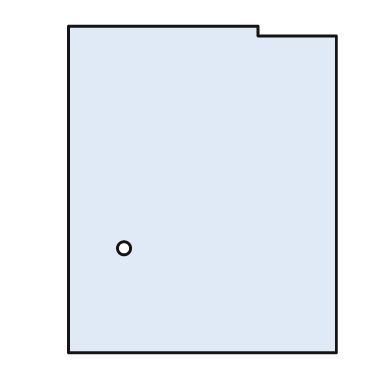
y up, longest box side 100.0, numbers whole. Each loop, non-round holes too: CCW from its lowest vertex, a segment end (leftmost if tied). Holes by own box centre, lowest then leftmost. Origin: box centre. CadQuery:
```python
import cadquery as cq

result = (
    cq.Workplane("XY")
    .moveTo(-41.0, -50.0)
    .lineTo(41.0, -50.0)
    .lineTo(41.0, 47.0)
    .lineTo(17.0, 47.0)
    .lineTo(17.0, 50.0)
    .lineTo(-41.0, 50.0)
    .close()
    .moveTo(-24.0, -18.0)
    .circle(2.0)
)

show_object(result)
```